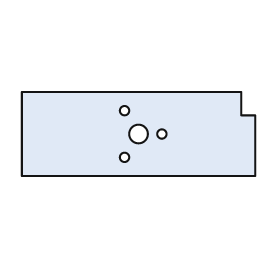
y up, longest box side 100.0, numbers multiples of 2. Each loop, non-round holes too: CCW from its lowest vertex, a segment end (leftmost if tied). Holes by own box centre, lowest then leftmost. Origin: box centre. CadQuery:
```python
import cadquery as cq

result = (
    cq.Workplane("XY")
    .moveTo(-50.0, -18.0)
    .lineTo(50.0, -18.0)
    .lineTo(50.0, 8.0)
    .lineTo(44.0, 8.0)
    .lineTo(44.0, 18.0)
    .lineTo(-50.0, 18.0)
    .close()
    .moveTo(-6.0, -10.0)
    .circle(2.0)
    .moveTo(0.0, 0.0)
    .circle(4.0)
    .moveTo(10.0, 0.0)
    .circle(2.0)
    .moveTo(-6.0, 10.0)
    .circle(2.0)
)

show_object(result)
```